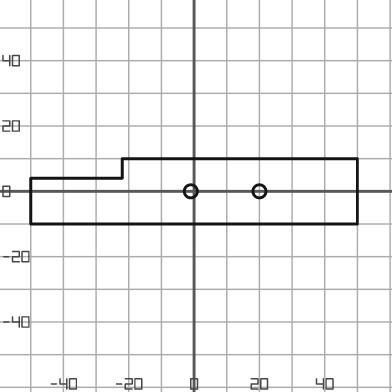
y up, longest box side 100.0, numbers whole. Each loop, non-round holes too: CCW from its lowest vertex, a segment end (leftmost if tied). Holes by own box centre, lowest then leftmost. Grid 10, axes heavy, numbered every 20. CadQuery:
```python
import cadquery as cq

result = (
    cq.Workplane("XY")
    .moveTo(-50.0, -10.0)
    .lineTo(50.0, -10.0)
    .lineTo(50.0, 10.0)
    .lineTo(-22.0, 10.0)
    .lineTo(-22.0, 4.0)
    .lineTo(-50.0, 4.0)
    .close()
    .moveTo(-1.0, 0.0)
    .circle(2.0)
    .moveTo(20.0, 0.0)
    .circle(2.0)
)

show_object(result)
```